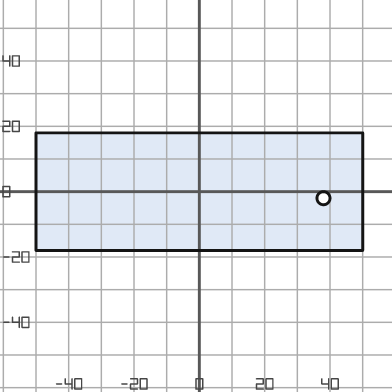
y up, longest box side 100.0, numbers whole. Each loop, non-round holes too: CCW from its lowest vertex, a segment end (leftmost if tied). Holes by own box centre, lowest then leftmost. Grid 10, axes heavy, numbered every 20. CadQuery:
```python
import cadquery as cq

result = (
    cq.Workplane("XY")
    .moveTo(-50.0, -18.0)
    .lineTo(50.0, -18.0)
    .lineTo(50.0, 18.0)
    .lineTo(-50.0, 18.0)
    .close()
    .moveTo(38.0, -2.0)
    .circle(2.0)
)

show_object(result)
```